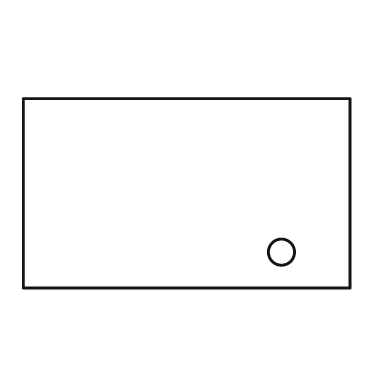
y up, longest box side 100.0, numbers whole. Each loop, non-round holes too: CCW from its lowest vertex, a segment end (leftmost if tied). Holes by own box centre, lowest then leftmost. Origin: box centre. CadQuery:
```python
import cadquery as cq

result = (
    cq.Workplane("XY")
    .moveTo(-50.0, -29.0)
    .lineTo(50.0, -29.0)
    .lineTo(50.0, 29.0)
    .lineTo(-50.0, 29.0)
    .close()
    .moveTo(29.0, -18.0)
    .circle(4.0)
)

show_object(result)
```